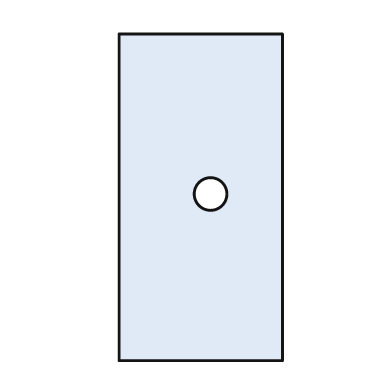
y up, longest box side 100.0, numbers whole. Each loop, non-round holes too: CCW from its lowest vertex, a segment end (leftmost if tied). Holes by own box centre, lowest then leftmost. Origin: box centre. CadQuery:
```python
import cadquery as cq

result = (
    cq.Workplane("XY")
    .moveTo(-25.0, -50.0)
    .lineTo(25.0, -50.0)
    .lineTo(25.0, 50.0)
    .lineTo(-25.0, 50.0)
    .close()
    .moveTo(3.0, 1.0)
    .circle(5.0)
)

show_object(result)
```